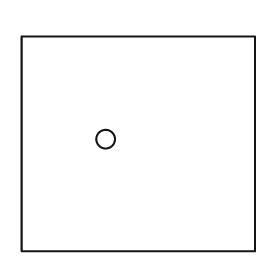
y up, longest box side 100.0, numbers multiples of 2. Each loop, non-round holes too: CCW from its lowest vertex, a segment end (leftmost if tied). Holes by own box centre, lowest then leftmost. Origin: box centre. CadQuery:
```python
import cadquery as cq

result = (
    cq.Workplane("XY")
    .moveTo(-50.0, -46.0)
    .lineTo(50.0, -46.0)
    .lineTo(50.0, 46.0)
    .lineTo(-50.0, 46.0)
    .close()
    .moveTo(-14.0, 2.0)
    .circle(4.0)
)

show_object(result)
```